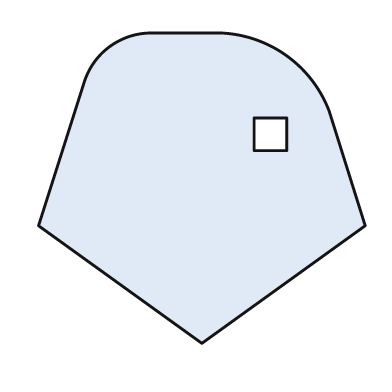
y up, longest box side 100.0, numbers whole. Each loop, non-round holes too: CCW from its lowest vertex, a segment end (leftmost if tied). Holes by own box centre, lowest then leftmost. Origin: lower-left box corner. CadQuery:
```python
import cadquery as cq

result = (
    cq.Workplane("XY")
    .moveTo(50.0, 0.0)
    .lineTo(100.0, 36.0)
    .lineTo(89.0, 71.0)
    .threePointArc((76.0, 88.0), (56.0, 95.0))
    .lineTo(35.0, 95.0)
    .threePointArc((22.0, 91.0), (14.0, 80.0))
    .lineTo(0.0, 36.0)
    .close()
    .moveTo(66.0, 59.0)
    .lineTo(76.0, 59.0)
    .lineTo(76.0, 69.0)
    .lineTo(66.0, 69.0)
    .close()
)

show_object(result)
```